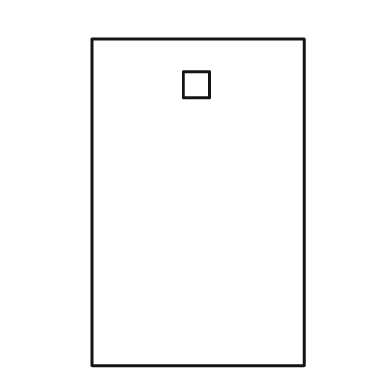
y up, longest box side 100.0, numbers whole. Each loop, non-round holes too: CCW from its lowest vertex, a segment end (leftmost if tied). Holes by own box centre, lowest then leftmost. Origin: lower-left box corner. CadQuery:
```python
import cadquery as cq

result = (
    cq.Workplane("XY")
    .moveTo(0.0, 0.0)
    .lineTo(65.0, 0.0)
    .lineTo(65.0, 100.0)
    .lineTo(0.0, 100.0)
    .close()
    .moveTo(28.0, 82.0)
    .lineTo(36.0, 82.0)
    .lineTo(36.0, 90.0)
    .lineTo(28.0, 90.0)
    .close()
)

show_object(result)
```